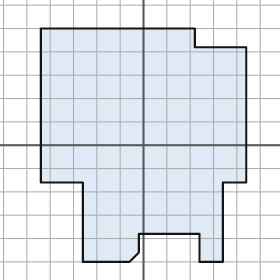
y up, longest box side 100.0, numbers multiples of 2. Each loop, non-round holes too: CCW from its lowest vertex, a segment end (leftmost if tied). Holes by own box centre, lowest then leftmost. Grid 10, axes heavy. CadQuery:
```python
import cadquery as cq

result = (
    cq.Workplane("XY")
    .moveTo(-26.0, -50.0)
    .lineTo(-6.0, -50.0)
    .lineTo(-2.0, -46.0)
    .lineTo(-2.0, -38.0)
    .lineTo(24.0, -38.0)
    .lineTo(24.0, -50.0)
    .lineTo(34.0, -50.0)
    .lineTo(34.0, -16.0)
    .lineTo(44.0, -16.0)
    .lineTo(44.0, 42.0)
    .lineTo(22.0, 42.0)
    .lineTo(22.0, 50.0)
    .lineTo(-44.0, 50.0)
    .lineTo(-44.0, -16.0)
    .lineTo(-26.0, -16.0)
    .close()
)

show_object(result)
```